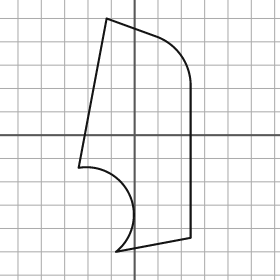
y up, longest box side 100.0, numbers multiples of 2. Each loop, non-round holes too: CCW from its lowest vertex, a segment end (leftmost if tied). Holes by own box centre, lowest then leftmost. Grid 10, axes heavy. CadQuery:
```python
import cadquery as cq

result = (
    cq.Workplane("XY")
    .moveTo(-8.0, -50.0)
    .lineTo(24.0, -44.0)
    .lineTo(24.0, 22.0)
    .threePointArc((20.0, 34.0), (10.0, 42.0))
    .lineTo(-12.0, 50.0)
    .lineTo(-24.0, -14.0)
    .threePointArc((-2.0, -26.0), (-8.0, -50.0))
    .close()
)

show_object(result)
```